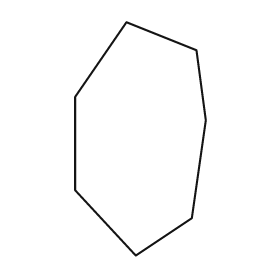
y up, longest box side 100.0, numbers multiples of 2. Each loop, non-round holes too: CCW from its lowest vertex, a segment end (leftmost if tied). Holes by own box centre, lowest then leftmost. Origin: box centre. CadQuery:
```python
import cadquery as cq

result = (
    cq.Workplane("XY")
    .moveTo(-2.0, -50.0)
    .lineTo(22.0, -34.0)
    .lineTo(28.0, 8.0)
    .lineTo(24.0, 38.0)
    .lineTo(-6.0, 50.0)
    .lineTo(-28.0, 18.0)
    .lineTo(-28.0, -22.0)
    .close()
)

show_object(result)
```